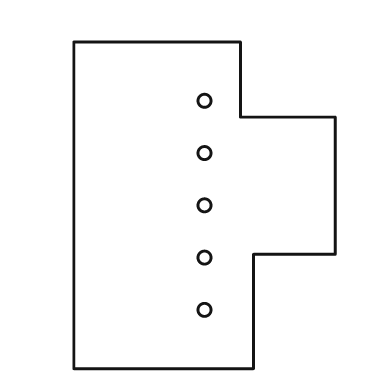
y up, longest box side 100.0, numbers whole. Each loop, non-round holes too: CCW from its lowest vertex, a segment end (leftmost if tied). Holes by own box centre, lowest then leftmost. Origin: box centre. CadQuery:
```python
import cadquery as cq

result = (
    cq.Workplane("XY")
    .moveTo(-40.0, -50.0)
    .lineTo(15.0, -50.0)
    .lineTo(15.0, -15.0)
    .lineTo(40.0, -15.0)
    .lineTo(40.0, 27.0)
    .lineTo(11.0, 27.0)
    .lineTo(11.0, 50.0)
    .lineTo(-40.0, 50.0)
    .close()
    .moveTo(0.0, -32.0)
    .circle(2.0)
    .moveTo(0.0, -16.0)
    .circle(2.0)
    .moveTo(0.0, 0.0)
    .circle(2.0)
    .moveTo(0.0, 16.0)
    .circle(2.0)
    .moveTo(0.0, 32.0)
    .circle(2.0)
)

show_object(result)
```